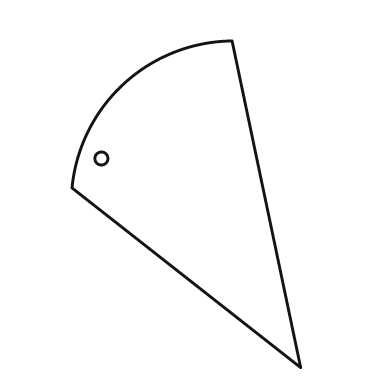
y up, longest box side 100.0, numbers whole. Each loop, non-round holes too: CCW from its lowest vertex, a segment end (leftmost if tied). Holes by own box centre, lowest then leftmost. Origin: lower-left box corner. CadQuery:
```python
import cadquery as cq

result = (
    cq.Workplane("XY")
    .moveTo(70.0, 0.0)
    .lineTo(49.0, 100.0)
    .threePointArc((16.0, 87.0), (0.0, 55.0))
    .close()
    .moveTo(9.0, 64.0)
    .circle(2.0)
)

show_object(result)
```